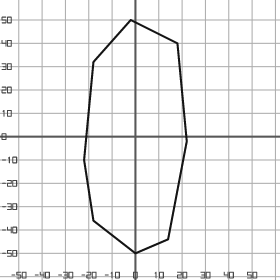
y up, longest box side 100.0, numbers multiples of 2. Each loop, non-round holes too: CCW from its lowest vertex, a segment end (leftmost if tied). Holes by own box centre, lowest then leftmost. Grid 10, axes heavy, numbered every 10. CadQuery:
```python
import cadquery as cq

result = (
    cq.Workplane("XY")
    .moveTo(0.0, -50.0)
    .lineTo(14.0, -44.0)
    .lineTo(22.0, -2.0)
    .lineTo(18.0, 40.0)
    .lineTo(-2.0, 50.0)
    .lineTo(-18.0, 32.0)
    .lineTo(-22.0, -10.0)
    .lineTo(-18.0, -36.0)
    .close()
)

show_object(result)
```